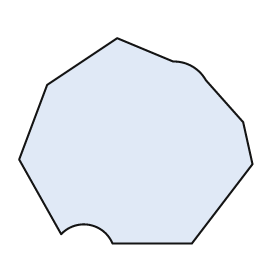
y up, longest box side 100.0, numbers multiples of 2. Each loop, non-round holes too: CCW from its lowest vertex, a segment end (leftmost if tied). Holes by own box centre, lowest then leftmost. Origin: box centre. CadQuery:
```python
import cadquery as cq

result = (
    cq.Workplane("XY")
    .moveTo(-10.0, -44.0)
    .lineTo(24.0, -44.0)
    .lineTo(50.0, -10.0)
    .lineTo(46.0, 8.0)
    .lineTo(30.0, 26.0)
    .threePointArc((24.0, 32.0), (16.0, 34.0))
    .lineTo(-8.0, 44.0)
    .lineTo(-38.0, 24.0)
    .lineTo(-50.0, -8.0)
    .lineTo(-32.0, -40.0)
    .threePointArc((-20.0, -36.0), (-10.0, -44.0))
    .close()
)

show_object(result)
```